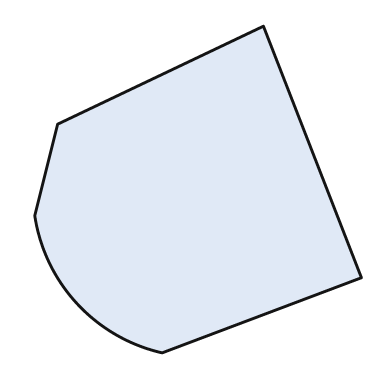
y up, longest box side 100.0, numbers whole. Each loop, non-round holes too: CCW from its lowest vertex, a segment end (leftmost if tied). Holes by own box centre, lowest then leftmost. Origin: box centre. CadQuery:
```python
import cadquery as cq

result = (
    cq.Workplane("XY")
    .moveTo(-11.0, -50.0)
    .lineTo(50.0, -27.0)
    .lineTo(20.0, 50.0)
    .lineTo(-43.0, 20.0)
    .lineTo(-50.0, -8.0)
    .threePointArc((-37.0, -35.0), (-11.0, -50.0))
    .close()
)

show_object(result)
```